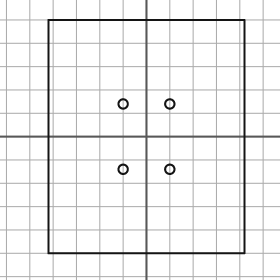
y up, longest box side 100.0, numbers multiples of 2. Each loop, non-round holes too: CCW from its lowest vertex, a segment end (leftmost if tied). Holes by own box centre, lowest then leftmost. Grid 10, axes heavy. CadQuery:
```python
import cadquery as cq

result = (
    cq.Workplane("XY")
    .moveTo(-42.0, -50.0)
    .lineTo(42.0, -50.0)
    .lineTo(42.0, 50.0)
    .lineTo(-42.0, 50.0)
    .close()
    .moveTo(-10.0, -14.0)
    .circle(2.0)
    .moveTo(10.0, -14.0)
    .circle(2.0)
    .moveTo(-10.0, 14.0)
    .circle(2.0)
    .moveTo(10.0, 14.0)
    .circle(2.0)
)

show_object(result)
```